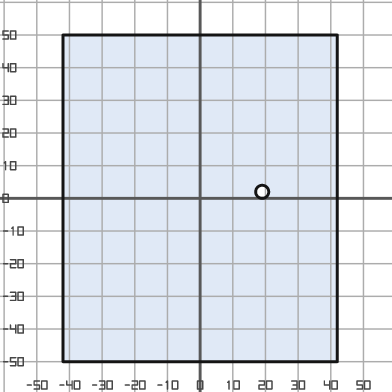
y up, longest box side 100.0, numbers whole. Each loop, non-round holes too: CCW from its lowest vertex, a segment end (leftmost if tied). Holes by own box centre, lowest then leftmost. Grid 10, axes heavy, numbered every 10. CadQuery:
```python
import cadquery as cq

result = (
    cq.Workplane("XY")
    .moveTo(-42.0, -50.0)
    .lineTo(42.0, -50.0)
    .lineTo(42.0, 50.0)
    .lineTo(-42.0, 50.0)
    .close()
    .moveTo(19.0, 2.0)
    .circle(2.0)
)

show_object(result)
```